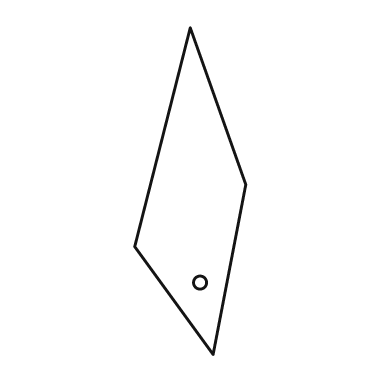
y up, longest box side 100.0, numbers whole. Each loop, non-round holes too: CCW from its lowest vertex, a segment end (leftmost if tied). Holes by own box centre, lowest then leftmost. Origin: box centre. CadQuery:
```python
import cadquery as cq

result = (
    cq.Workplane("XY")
    .moveTo(7.0, -50.0)
    .lineTo(17.0, 2.0)
    .lineTo(0.0, 50.0)
    .lineTo(-17.0, -17.0)
    .close()
    .moveTo(3.0, -28.0)
    .circle(2.0)
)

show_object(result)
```